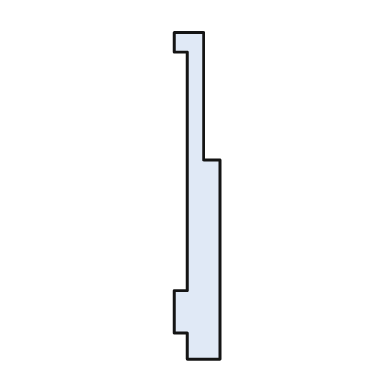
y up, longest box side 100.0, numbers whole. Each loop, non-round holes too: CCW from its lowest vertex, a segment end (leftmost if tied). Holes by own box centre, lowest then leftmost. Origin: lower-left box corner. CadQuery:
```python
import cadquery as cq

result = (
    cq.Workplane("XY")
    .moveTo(4.0, 0.0)
    .lineTo(14.0, 0.0)
    .lineTo(14.0, 61.0)
    .lineTo(9.0, 61.0)
    .lineTo(9.0, 100.0)
    .lineTo(0.0, 100.0)
    .lineTo(0.0, 94.0)
    .lineTo(4.0, 94.0)
    .lineTo(4.0, 21.0)
    .lineTo(0.0, 21.0)
    .lineTo(0.0, 8.0)
    .lineTo(4.0, 8.0)
    .close()
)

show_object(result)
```